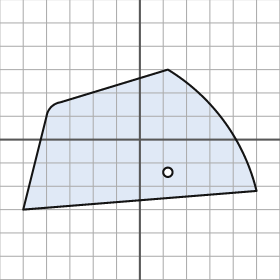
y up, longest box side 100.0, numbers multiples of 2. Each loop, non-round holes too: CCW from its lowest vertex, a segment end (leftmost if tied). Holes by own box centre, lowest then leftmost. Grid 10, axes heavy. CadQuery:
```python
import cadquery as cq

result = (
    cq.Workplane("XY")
    .moveTo(-50.0, -30.0)
    .lineTo(50.0, -22.0)
    .threePointArc((36.0, 8.0), (12.0, 30.0))
    .lineTo(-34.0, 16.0)
    .threePointArc((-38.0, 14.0), (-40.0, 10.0))
    .close()
    .moveTo(12.0, -14.0)
    .circle(2.0)
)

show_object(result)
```